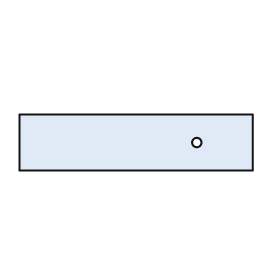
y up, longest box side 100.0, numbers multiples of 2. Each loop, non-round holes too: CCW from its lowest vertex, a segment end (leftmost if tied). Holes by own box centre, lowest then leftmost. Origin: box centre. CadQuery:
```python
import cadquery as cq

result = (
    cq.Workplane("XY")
    .moveTo(-50.0, -12.0)
    .lineTo(50.0, -12.0)
    .lineTo(50.0, 12.0)
    .lineTo(-50.0, 12.0)
    .close()
    .moveTo(26.0, 0.0)
    .circle(2.0)
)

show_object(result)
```